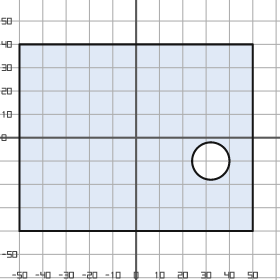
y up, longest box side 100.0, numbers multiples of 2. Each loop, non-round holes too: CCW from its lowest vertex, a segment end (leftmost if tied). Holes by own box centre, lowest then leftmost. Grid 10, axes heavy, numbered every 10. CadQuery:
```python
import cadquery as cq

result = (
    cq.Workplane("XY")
    .moveTo(-50.0, -40.0)
    .lineTo(50.0, -40.0)
    .lineTo(50.0, 40.0)
    .lineTo(-50.0, 40.0)
    .close()
    .moveTo(32.0, -10.0)
    .circle(8.0)
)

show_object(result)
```